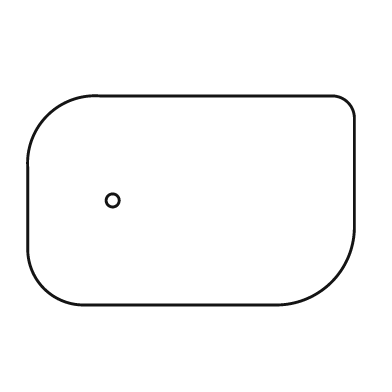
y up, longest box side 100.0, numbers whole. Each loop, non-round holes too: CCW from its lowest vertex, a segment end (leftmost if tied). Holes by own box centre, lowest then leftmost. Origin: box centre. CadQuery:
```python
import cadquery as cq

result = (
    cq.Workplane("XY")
    .moveTo(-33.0, -32.0)
    .lineTo(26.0, -32.0)
    .threePointArc((43.0, -25.0), (50.0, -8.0))
    .lineTo(50.0, 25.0)
    .threePointArc((48.0, 30.0), (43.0, 32.0))
    .lineTo(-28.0, 32.0)
    .threePointArc((-44.0, 26.0), (-50.0, 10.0))
    .lineTo(-50.0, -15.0)
    .threePointArc((-45.0, -27.0), (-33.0, -32.0))
    .close()
    .moveTo(-24.0, 0.0)
    .circle(2.0)
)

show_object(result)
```